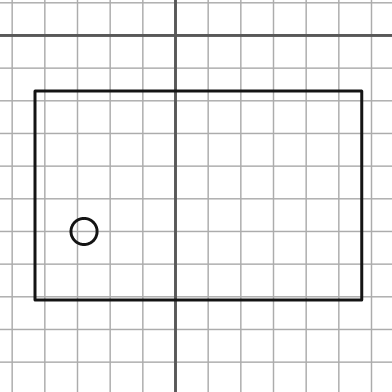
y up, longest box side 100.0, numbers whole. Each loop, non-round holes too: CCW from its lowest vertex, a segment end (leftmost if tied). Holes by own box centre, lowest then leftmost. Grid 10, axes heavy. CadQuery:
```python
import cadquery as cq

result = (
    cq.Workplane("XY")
    .moveTo(-43.0, -81.0)
    .lineTo(57.0, -81.0)
    .lineTo(57.0, -17.0)
    .lineTo(-43.0, -17.0)
    .close()
    .moveTo(-28.0, -60.0)
    .circle(4.0)
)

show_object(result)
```